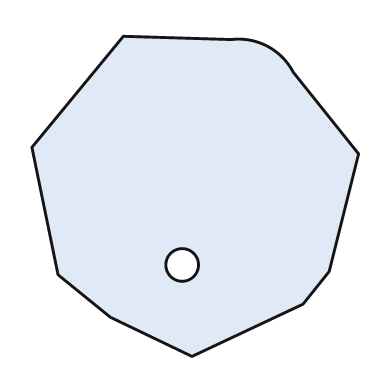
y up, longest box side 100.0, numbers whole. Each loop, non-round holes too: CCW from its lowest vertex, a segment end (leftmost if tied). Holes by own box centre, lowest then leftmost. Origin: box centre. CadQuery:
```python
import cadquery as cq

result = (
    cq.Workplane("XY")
    .moveTo(-1.0, -49.0)
    .lineTo(33.0, -33.0)
    .lineTo(41.0, -23.0)
    .lineTo(50.0, 13.0)
    .lineTo(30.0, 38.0)
    .threePointArc((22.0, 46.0), (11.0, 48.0))
    .lineTo(-22.0, 49.0)
    .lineTo(-50.0, 15.0)
    .lineTo(-42.0, -24.0)
    .lineTo(-26.0, -37.0)
    .close()
    .moveTo(-4.0, -21.0)
    .circle(5.0)
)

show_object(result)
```